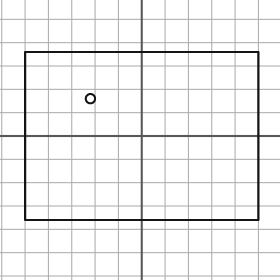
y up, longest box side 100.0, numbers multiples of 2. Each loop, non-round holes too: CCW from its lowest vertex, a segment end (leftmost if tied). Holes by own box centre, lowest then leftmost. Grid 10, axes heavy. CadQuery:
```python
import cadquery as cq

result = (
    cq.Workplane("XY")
    .moveTo(-50.0, -36.0)
    .lineTo(50.0, -36.0)
    .lineTo(50.0, 36.0)
    .lineTo(-50.0, 36.0)
    .close()
    .moveTo(-22.0, 16.0)
    .circle(2.0)
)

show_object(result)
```